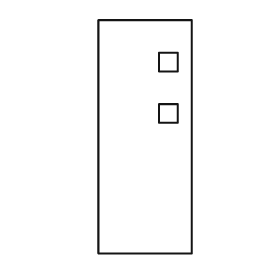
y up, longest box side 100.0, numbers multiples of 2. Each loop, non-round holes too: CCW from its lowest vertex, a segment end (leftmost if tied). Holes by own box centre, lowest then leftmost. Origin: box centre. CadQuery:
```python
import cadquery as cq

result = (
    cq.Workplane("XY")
    .moveTo(-20.0, -50.0)
    .lineTo(20.0, -50.0)
    .lineTo(20.0, 50.0)
    .lineTo(-20.0, 50.0)
    .close()
    .moveTo(6.0, 6.0)
    .lineTo(14.0, 6.0)
    .lineTo(14.0, 14.0)
    .lineTo(6.0, 14.0)
    .close()
    .moveTo(6.0, 28.0)
    .lineTo(14.0, 28.0)
    .lineTo(14.0, 36.0)
    .lineTo(6.0, 36.0)
    .close()
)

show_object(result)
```